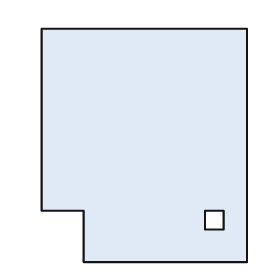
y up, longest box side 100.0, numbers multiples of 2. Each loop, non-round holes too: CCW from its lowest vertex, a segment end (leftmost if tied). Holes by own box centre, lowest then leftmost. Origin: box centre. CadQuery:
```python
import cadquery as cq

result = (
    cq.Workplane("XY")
    .moveTo(-26.0, -50.0)
    .lineTo(44.0, -50.0)
    .lineTo(44.0, 50.0)
    .lineTo(-44.0, 50.0)
    .lineTo(-44.0, -28.0)
    .lineTo(-26.0, -28.0)
    .close()
    .moveTo(26.0, -36.0)
    .lineTo(34.0, -36.0)
    .lineTo(34.0, -28.0)
    .lineTo(26.0, -28.0)
    .close()
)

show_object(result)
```